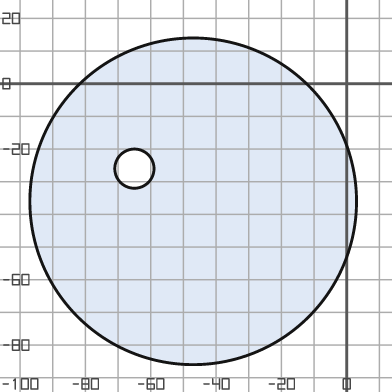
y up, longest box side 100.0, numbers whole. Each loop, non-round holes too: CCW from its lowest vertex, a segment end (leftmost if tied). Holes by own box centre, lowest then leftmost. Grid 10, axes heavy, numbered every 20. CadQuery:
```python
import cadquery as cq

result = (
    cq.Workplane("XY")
    .moveTo(-47.0, -36.0)
    .circle(50.0)
    .moveTo(-65.0, -26.0)
    .circle(6.0)
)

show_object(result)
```